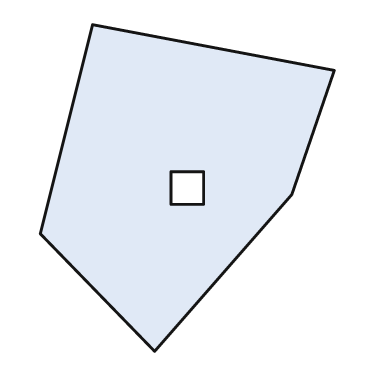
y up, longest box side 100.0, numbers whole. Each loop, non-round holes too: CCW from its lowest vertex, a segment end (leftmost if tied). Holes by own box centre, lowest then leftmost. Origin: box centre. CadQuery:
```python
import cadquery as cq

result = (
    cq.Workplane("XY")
    .moveTo(-10.0, -50.0)
    .lineTo(32.0, -2.0)
    .lineTo(45.0, 36.0)
    .lineTo(-29.0, 50.0)
    .lineTo(-45.0, -14.0)
    .close()
    .moveTo(-5.0, -5.0)
    .lineTo(5.0, -5.0)
    .lineTo(5.0, 5.0)
    .lineTo(-5.0, 5.0)
    .close()
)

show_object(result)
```